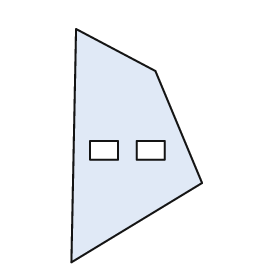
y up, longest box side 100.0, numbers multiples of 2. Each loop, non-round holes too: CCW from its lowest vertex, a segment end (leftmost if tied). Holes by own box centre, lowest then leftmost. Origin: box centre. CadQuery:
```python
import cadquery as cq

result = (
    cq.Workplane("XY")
    .moveTo(-28.0, -50.0)
    .lineTo(28.0, -16.0)
    .lineTo(8.0, 32.0)
    .lineTo(-26.0, 50.0)
    .close()
    .moveTo(-20.0, -6.0)
    .lineTo(-8.0, -6.0)
    .lineTo(-8.0, 2.0)
    .lineTo(-20.0, 2.0)
    .close()
    .moveTo(0.0, -6.0)
    .lineTo(12.0, -6.0)
    .lineTo(12.0, 2.0)
    .lineTo(0.0, 2.0)
    .close()
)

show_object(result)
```